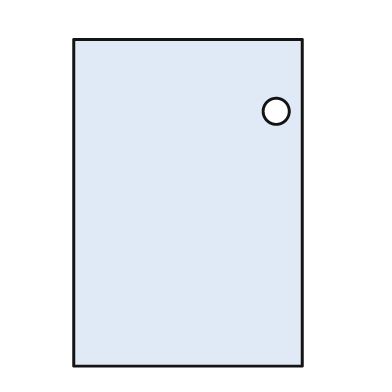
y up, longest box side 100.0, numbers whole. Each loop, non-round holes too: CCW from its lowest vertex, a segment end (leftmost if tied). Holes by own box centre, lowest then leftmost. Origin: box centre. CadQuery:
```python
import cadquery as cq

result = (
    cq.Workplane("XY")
    .moveTo(-35.0, -50.0)
    .lineTo(35.0, -50.0)
    .lineTo(35.0, 50.0)
    .lineTo(-35.0, 50.0)
    .close()
    .moveTo(27.0, 28.0)
    .circle(4.0)
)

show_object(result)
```